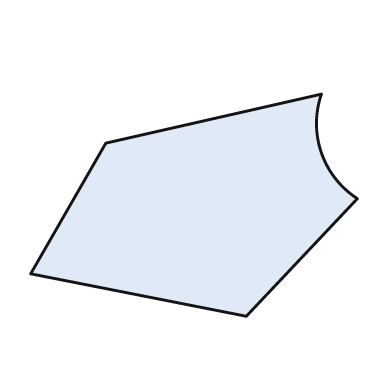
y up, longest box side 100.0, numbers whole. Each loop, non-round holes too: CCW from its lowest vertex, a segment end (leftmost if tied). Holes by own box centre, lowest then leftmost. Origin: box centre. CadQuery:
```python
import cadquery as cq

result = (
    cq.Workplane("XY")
    .moveTo(16.0, -34.0)
    .lineTo(50.0, 2.0)
    .threePointArc((39.0, 16.0), (39.0, 34.0))
    .lineTo(-27.0, 19.0)
    .lineTo(-50.0, -21.0)
    .close()
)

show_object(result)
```